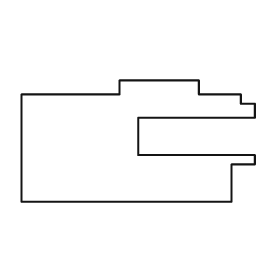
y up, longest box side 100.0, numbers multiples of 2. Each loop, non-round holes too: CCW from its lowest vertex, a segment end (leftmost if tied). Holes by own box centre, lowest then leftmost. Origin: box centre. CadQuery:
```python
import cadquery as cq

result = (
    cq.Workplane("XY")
    .moveTo(-50.0, -26.0)
    .lineTo(40.0, -26.0)
    .lineTo(40.0, -10.0)
    .lineTo(50.0, -10.0)
    .lineTo(50.0, -6.0)
    .lineTo(0.0, -6.0)
    .lineTo(0.0, 10.0)
    .lineTo(50.0, 10.0)
    .lineTo(50.0, 16.0)
    .lineTo(44.0, 16.0)
    .lineTo(44.0, 20.0)
    .lineTo(26.0, 20.0)
    .lineTo(26.0, 26.0)
    .lineTo(-8.0, 26.0)
    .lineTo(-8.0, 20.0)
    .lineTo(-50.0, 20.0)
    .close()
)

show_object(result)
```